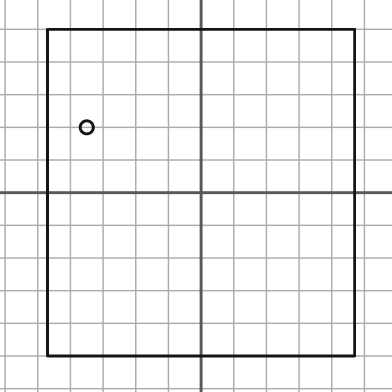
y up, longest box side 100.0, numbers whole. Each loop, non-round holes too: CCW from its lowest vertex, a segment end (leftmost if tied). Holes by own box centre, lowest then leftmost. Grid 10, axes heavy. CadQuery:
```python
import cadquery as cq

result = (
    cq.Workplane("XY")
    .moveTo(-47.0, -50.0)
    .lineTo(47.0, -50.0)
    .lineTo(47.0, 50.0)
    .lineTo(-47.0, 50.0)
    .close()
    .moveTo(-35.0, 20.0)
    .circle(2.0)
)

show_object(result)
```